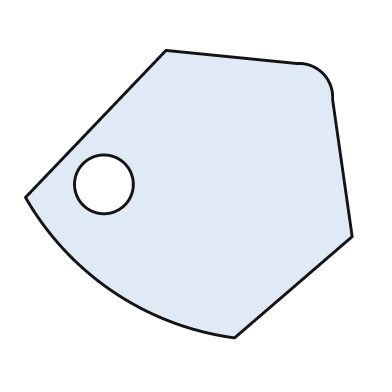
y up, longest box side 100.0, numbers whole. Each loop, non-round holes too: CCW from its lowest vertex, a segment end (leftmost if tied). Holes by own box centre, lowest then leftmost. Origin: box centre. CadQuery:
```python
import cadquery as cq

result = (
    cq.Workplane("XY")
    .moveTo(14.0, -44.0)
    .lineTo(50.0, -13.0)
    .lineTo(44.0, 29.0)
    .threePointArc((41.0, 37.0), (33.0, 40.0))
    .lineTo(-7.0, 44.0)
    .lineTo(-50.0, -1.0)
    .threePointArc((-23.0, -30.0), (14.0, -44.0))
    .close()
    .moveTo(-26.0, 3.0)
    .circle(9.0)
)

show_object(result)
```